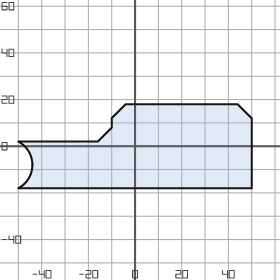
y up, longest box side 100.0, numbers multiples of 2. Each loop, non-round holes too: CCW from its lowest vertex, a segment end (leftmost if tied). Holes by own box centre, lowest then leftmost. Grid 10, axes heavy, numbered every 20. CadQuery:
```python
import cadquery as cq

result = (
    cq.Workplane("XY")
    .moveTo(-50.0, -18.0)
    .lineTo(50.0, -18.0)
    .lineTo(50.0, 12.0)
    .lineTo(44.0, 18.0)
    .lineTo(-4.0, 18.0)
    .lineTo(-10.0, 12.0)
    .lineTo(-10.0, 8.0)
    .lineTo(-16.0, 2.0)
    .lineTo(-50.0, 2.0)
    .threePointArc((-44.0, -8.0), (-50.0, -18.0))
    .close()
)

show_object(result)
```